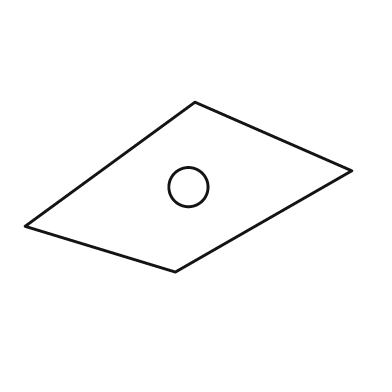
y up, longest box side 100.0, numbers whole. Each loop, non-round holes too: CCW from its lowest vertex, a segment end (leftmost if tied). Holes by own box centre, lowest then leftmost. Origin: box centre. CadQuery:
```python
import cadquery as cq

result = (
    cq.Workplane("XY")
    .moveTo(-4.0, -26.0)
    .lineTo(50.0, 5.0)
    .lineTo(2.0, 26.0)
    .lineTo(-50.0, -12.0)
    .close()
    .moveTo(0.0, 0.0)
    .circle(6.0)
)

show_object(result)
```